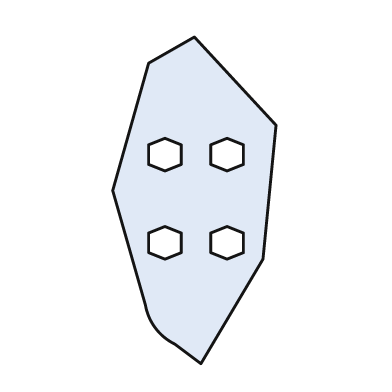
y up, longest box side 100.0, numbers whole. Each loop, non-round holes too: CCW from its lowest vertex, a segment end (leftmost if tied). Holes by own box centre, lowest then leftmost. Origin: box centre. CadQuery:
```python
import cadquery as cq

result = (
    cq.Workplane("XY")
    .moveTo(2.0, -50.0)
    .lineTo(21.0, -18.0)
    .lineTo(25.0, 23.0)
    .lineTo(0.0, 50.0)
    .lineTo(-14.0, 42.0)
    .lineTo(-25.0, 3.0)
    .lineTo(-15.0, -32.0)
    .threePointArc((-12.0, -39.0), (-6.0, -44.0))
    .close()
    .moveTo(-9.0, -18.0)
    .lineTo(-4.0, -16.0)
    .lineTo(-4.0, -10.0)
    .lineTo(-9.0, -8.0)
    .lineTo(-14.0, -10.0)
    .lineTo(-14.0, -16.0)
    .close()
    .moveTo(10.0, -18.0)
    .lineTo(15.0, -16.0)
    .lineTo(15.0, -10.0)
    .lineTo(10.0, -8.0)
    .lineTo(5.0, -10.0)
    .lineTo(5.0, -16.0)
    .close()
    .moveTo(-9.0, 9.0)
    .lineTo(-4.0, 11.0)
    .lineTo(-4.0, 17.0)
    .lineTo(-9.0, 19.0)
    .lineTo(-14.0, 17.0)
    .lineTo(-14.0, 11.0)
    .close()
    .moveTo(10.0, 9.0)
    .lineTo(15.0, 11.0)
    .lineTo(15.0, 17.0)
    .lineTo(10.0, 19.0)
    .lineTo(5.0, 17.0)
    .lineTo(5.0, 11.0)
    .close()
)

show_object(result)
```